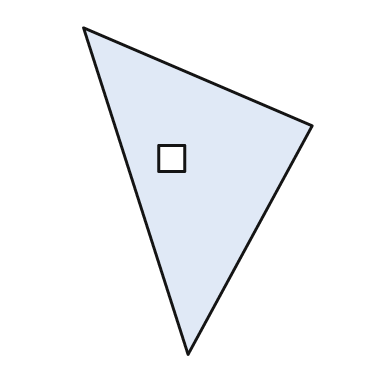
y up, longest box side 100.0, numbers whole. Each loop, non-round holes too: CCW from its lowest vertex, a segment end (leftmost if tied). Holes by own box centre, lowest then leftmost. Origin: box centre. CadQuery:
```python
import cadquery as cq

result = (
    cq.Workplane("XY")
    .moveTo(-3.0, -50.0)
    .lineTo(35.0, 20.0)
    .lineTo(-35.0, 50.0)
    .close()
    .moveTo(-12.0, 6.0)
    .lineTo(-4.0, 6.0)
    .lineTo(-4.0, 14.0)
    .lineTo(-12.0, 14.0)
    .close()
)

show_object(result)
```